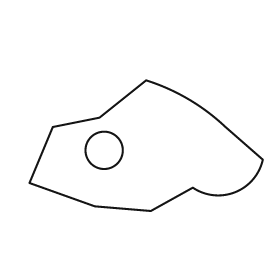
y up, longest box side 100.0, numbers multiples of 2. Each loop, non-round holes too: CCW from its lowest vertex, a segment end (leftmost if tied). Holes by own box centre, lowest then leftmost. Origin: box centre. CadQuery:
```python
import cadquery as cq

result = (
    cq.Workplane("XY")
    .moveTo(2.0, -28.0)
    .lineTo(20.0, -18.0)
    .threePointArc((38.0, -20.0), (50.0, -6.0))
    .lineTo(34.0, 8.0)
    .threePointArc((18.0, 20.0), (0.0, 28.0))
    .lineTo(-20.0, 12.0)
    .lineTo(-40.0, 8.0)
    .lineTo(-50.0, -16.0)
    .lineTo(-22.0, -26.0)
    .close()
    .moveTo(-18.0, -2.0)
    .circle(8.0)
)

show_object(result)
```